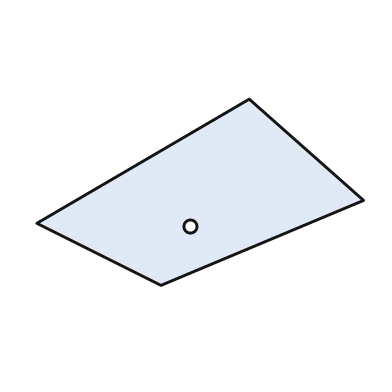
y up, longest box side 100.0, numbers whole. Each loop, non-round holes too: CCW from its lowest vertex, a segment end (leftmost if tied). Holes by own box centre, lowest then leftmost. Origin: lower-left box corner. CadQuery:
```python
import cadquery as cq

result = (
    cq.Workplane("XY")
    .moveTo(38.0, 0.0)
    .lineTo(100.0, 26.0)
    .lineTo(65.0, 57.0)
    .lineTo(0.0, 19.0)
    .close()
    .moveTo(47.0, 18.0)
    .circle(2.0)
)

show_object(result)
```